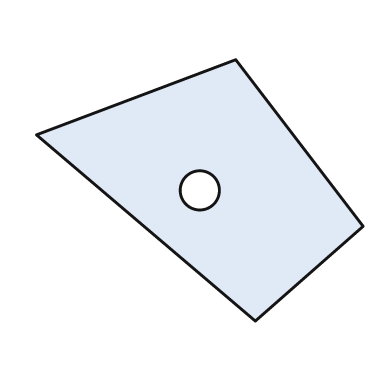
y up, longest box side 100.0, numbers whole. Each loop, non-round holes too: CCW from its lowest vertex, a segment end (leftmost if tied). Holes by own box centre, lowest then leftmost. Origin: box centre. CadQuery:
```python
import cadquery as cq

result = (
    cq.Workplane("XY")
    .moveTo(17.0, -40.0)
    .lineTo(50.0, -11.0)
    .lineTo(11.0, 40.0)
    .lineTo(-50.0, 17.0)
    .close()
    .moveTo(0.0, 0.0)
    .circle(6.0)
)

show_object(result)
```